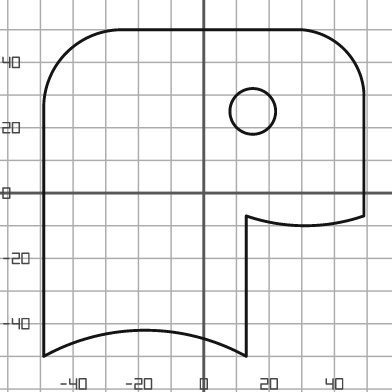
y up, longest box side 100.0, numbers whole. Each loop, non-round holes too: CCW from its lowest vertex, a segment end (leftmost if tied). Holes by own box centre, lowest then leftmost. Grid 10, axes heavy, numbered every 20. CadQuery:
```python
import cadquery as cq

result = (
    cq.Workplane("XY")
    .moveTo(-49.0, -50.0)
    .threePointArc((-18.0, -42.0), (13.0, -50.0))
    .lineTo(13.0, -7.0)
    .threePointArc((31.0, -10.0), (49.0, -7.0))
    .lineTo(49.0, 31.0)
    .threePointArc((43.0, 44.0), (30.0, 50.0))
    .lineTo(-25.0, 50.0)
    .threePointArc((-42.0, 43.0), (-49.0, 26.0))
    .close()
    .moveTo(15.0, 25.0)
    .circle(7.0)
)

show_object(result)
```